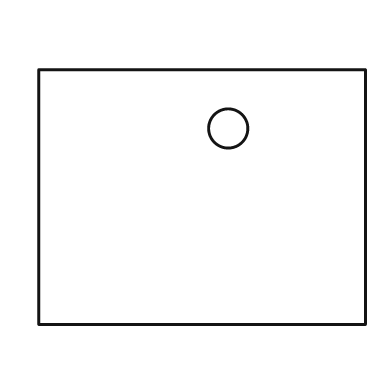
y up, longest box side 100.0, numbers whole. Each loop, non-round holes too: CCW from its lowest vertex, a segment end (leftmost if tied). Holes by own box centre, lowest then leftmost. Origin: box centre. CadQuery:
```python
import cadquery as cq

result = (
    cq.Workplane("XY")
    .moveTo(-50.0, -39.0)
    .lineTo(50.0, -39.0)
    .lineTo(50.0, 39.0)
    .lineTo(-50.0, 39.0)
    .close()
    .moveTo(8.0, 21.0)
    .circle(6.0)
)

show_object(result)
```